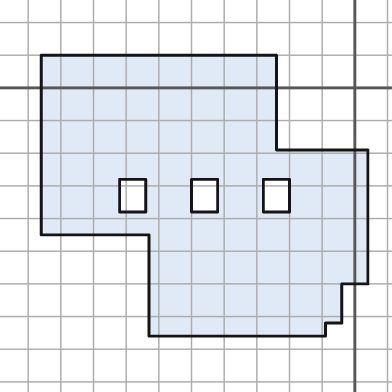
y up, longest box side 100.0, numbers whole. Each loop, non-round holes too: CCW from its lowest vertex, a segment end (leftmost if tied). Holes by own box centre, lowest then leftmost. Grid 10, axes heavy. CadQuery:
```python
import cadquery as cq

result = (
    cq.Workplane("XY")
    .moveTo(-63.0, -76.0)
    .lineTo(-9.0, -76.0)
    .lineTo(-9.0, -72.0)
    .lineTo(-4.0, -72.0)
    .lineTo(-4.0, -60.0)
    .lineTo(4.0, -60.0)
    .lineTo(4.0, -19.0)
    .lineTo(-24.0, -19.0)
    .lineTo(-24.0, 10.0)
    .lineTo(-96.0, 10.0)
    .lineTo(-96.0, -45.0)
    .lineTo(-63.0, -45.0)
    .close()
    .moveTo(-72.0, -38.0)
    .lineTo(-64.0, -38.0)
    .lineTo(-64.0, -28.0)
    .lineTo(-72.0, -28.0)
    .close()
    .moveTo(-50.0, -38.0)
    .lineTo(-42.0, -38.0)
    .lineTo(-42.0, -28.0)
    .lineTo(-50.0, -28.0)
    .close()
    .moveTo(-28.0, -38.0)
    .lineTo(-20.0, -38.0)
    .lineTo(-20.0, -28.0)
    .lineTo(-28.0, -28.0)
    .close()
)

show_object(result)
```